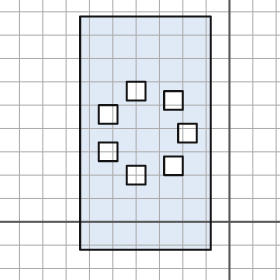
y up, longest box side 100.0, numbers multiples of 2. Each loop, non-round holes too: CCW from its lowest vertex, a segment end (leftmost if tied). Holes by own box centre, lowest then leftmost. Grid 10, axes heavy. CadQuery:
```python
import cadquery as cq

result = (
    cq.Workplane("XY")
    .moveTo(-64.0, -12.0)
    .lineTo(-8.0, -12.0)
    .lineTo(-8.0, 88.0)
    .lineTo(-64.0, 88.0)
    .close()
    .moveTo(-44.0, 16.0)
    .lineTo(-36.0, 16.0)
    .lineTo(-36.0, 24.0)
    .lineTo(-44.0, 24.0)
    .close()
    .moveTo(-28.0, 20.0)
    .lineTo(-20.0, 20.0)
    .lineTo(-20.0, 28.0)
    .lineTo(-28.0, 28.0)
    .close()
    .moveTo(-56.0, 26.0)
    .lineTo(-48.0, 26.0)
    .lineTo(-48.0, 34.0)
    .lineTo(-56.0, 34.0)
    .close()
    .moveTo(-22.0, 34.0)
    .lineTo(-14.0, 34.0)
    .lineTo(-14.0, 42.0)
    .lineTo(-22.0, 42.0)
    .close()
    .moveTo(-56.0, 42.0)
    .lineTo(-48.0, 42.0)
    .lineTo(-48.0, 50.0)
    .lineTo(-56.0, 50.0)
    .close()
    .moveTo(-28.0, 48.0)
    .lineTo(-20.0, 48.0)
    .lineTo(-20.0, 56.0)
    .lineTo(-28.0, 56.0)
    .close()
    .moveTo(-44.0, 52.0)
    .lineTo(-36.0, 52.0)
    .lineTo(-36.0, 60.0)
    .lineTo(-44.0, 60.0)
    .close()
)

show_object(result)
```